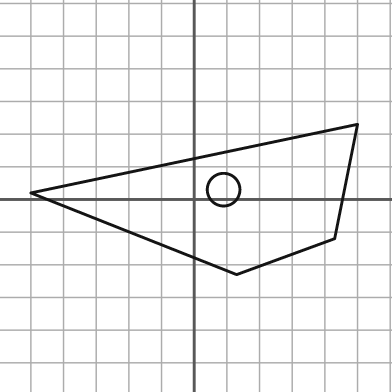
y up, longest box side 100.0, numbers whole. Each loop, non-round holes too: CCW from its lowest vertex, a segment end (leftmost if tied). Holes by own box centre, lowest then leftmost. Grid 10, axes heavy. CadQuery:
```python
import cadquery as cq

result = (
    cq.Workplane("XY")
    .moveTo(13.0, -23.0)
    .lineTo(43.0, -12.0)
    .lineTo(50.0, 23.0)
    .lineTo(-50.0, 2.0)
    .close()
    .moveTo(9.0, 3.0)
    .circle(5.0)
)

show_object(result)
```